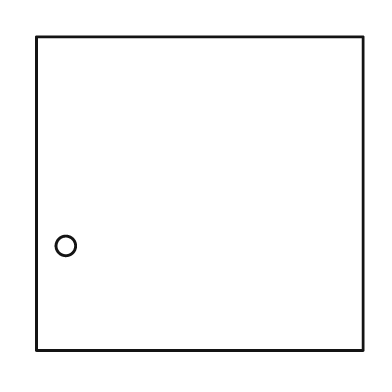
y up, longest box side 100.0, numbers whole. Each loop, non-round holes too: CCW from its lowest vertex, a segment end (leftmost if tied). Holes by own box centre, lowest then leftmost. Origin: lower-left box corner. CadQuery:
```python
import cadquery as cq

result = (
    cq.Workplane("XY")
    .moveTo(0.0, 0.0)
    .lineTo(100.0, 0.0)
    .lineTo(100.0, 96.0)
    .lineTo(0.0, 96.0)
    .close()
    .moveTo(9.0, 32.0)
    .circle(3.0)
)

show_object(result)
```